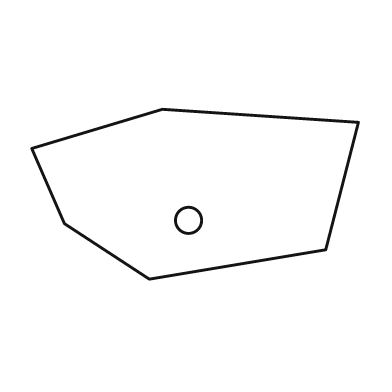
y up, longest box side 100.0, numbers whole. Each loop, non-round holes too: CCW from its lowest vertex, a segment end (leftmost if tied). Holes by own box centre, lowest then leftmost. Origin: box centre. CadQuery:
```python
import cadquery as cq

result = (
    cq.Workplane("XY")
    .moveTo(-14.0, -26.0)
    .lineTo(40.0, -17.0)
    .lineTo(50.0, 22.0)
    .lineTo(-10.0, 26.0)
    .lineTo(-50.0, 14.0)
    .lineTo(-40.0, -9.0)
    .close()
    .moveTo(-2.0, -8.0)
    .circle(4.0)
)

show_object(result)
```